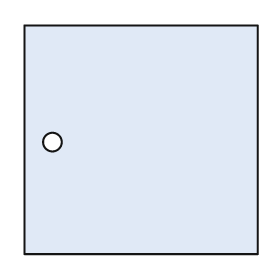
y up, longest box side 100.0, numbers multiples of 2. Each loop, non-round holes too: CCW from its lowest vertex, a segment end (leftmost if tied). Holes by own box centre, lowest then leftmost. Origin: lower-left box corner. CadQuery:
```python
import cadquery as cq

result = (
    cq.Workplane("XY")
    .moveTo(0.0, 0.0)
    .lineTo(100.0, 0.0)
    .lineTo(100.0, 98.0)
    .lineTo(0.0, 98.0)
    .close()
    .moveTo(12.0, 48.0)
    .circle(4.0)
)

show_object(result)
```